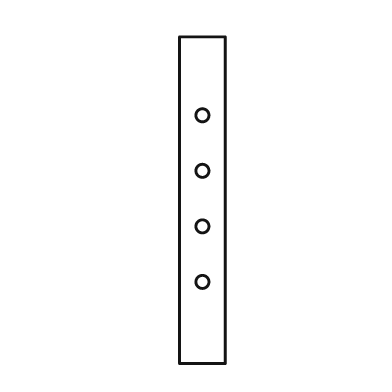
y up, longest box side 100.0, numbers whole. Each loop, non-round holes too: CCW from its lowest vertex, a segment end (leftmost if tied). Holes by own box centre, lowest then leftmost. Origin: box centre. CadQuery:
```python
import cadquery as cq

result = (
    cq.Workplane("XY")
    .moveTo(-7.0, -50.0)
    .lineTo(7.0, -50.0)
    .lineTo(7.0, 50.0)
    .lineTo(-7.0, 50.0)
    .close()
    .moveTo(0.0, -25.0)
    .circle(2.0)
    .moveTo(0.0, -8.0)
    .circle(2.0)
    .moveTo(0.0, 9.0)
    .circle(2.0)
    .moveTo(0.0, 26.0)
    .circle(2.0)
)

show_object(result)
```